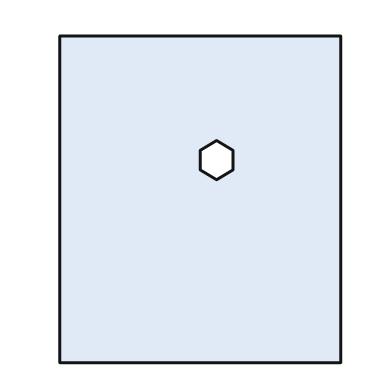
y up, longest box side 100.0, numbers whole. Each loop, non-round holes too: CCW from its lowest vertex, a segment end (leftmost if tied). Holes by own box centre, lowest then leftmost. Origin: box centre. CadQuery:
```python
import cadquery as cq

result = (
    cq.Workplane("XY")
    .moveTo(-43.0, -50.0)
    .lineTo(43.0, -50.0)
    .lineTo(43.0, 50.0)
    .lineTo(-43.0, 50.0)
    .close()
    .moveTo(5.0, 6.0)
    .lineTo(10.0, 9.0)
    .lineTo(10.0, 15.0)
    .lineTo(5.0, 18.0)
    .lineTo(0.0, 15.0)
    .lineTo(0.0, 9.0)
    .close()
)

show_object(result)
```